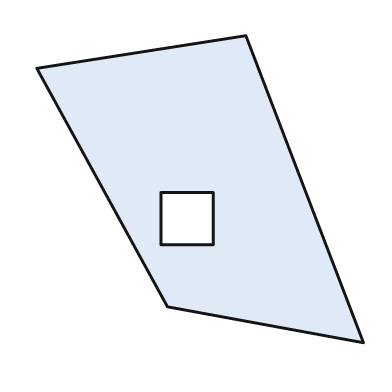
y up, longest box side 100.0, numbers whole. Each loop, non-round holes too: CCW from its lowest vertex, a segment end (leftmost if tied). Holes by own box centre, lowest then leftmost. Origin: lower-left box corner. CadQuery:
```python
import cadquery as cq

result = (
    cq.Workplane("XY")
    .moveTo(100.0, 0.0)
    .lineTo(64.0, 94.0)
    .lineTo(0.0, 84.0)
    .lineTo(40.0, 11.0)
    .close()
    .moveTo(38.0, 30.0)
    .lineTo(54.0, 30.0)
    .lineTo(54.0, 46.0)
    .lineTo(38.0, 46.0)
    .close()
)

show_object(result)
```